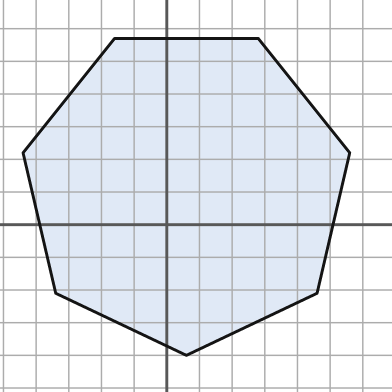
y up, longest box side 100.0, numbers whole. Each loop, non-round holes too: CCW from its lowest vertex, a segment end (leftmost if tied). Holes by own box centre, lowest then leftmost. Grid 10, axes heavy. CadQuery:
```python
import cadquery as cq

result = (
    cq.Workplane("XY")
    .moveTo(6.0, -40.0)
    .lineTo(46.0, -21.0)
    .lineTo(56.0, 22.0)
    .lineTo(28.0, 57.0)
    .lineTo(-16.0, 57.0)
    .lineTo(-44.0, 22.0)
    .lineTo(-34.0, -21.0)
    .close()
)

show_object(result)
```